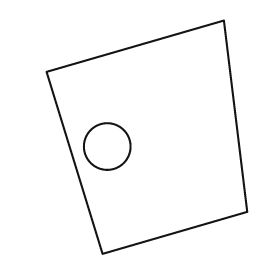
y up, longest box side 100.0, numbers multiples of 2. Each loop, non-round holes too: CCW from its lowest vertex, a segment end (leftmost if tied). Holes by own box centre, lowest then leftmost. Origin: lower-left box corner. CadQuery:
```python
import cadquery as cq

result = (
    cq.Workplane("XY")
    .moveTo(24.0, 0.0)
    .lineTo(86.0, 18.0)
    .lineTo(76.0, 100.0)
    .lineTo(0.0, 78.0)
    .close()
    .moveTo(26.0, 46.0)
    .circle(10.0)
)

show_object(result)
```